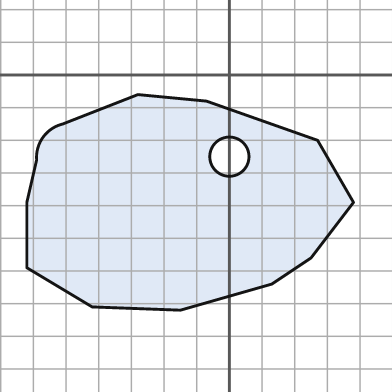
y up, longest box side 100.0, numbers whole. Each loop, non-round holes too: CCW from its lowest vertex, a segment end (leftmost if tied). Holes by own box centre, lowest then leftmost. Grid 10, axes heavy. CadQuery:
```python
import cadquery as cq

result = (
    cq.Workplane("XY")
    .moveTo(-15.0, -72.0)
    .lineTo(13.0, -64.0)
    .lineTo(25.0, -56.0)
    .lineTo(38.0, -39.0)
    .lineTo(27.0, -20.0)
    .lineTo(-7.0, -8.0)
    .lineTo(-28.0, -6.0)
    .lineTo(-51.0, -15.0)
    .threePointArc((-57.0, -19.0), (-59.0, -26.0))
    .lineTo(-62.0, -39.0)
    .lineTo(-62.0, -59.0)
    .lineTo(-42.0, -71.0)
    .close()
    .moveTo(0.0, -25.0)
    .circle(6.0)
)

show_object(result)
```